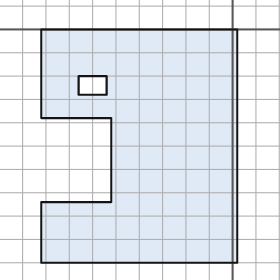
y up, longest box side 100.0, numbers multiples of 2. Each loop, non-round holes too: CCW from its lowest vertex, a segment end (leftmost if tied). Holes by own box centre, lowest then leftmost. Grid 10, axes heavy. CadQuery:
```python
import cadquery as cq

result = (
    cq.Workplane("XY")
    .moveTo(-82.0, -100.0)
    .lineTo(2.0, -100.0)
    .lineTo(2.0, 0.0)
    .lineTo(-82.0, 0.0)
    .lineTo(-82.0, -38.0)
    .lineTo(-52.0, -38.0)
    .lineTo(-52.0, -74.0)
    .lineTo(-82.0, -74.0)
    .close()
    .moveTo(-66.0, -28.0)
    .lineTo(-54.0, -28.0)
    .lineTo(-54.0, -20.0)
    .lineTo(-66.0, -20.0)
    .close()
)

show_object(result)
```